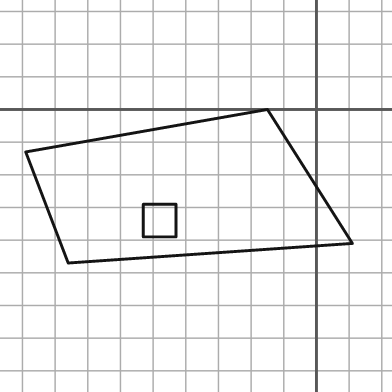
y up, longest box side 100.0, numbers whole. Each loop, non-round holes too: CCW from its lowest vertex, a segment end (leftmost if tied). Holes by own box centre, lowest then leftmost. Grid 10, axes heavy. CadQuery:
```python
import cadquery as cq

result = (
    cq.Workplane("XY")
    .moveTo(-76.0, -47.0)
    .lineTo(11.0, -41.0)
    .lineTo(-15.0, 0.0)
    .lineTo(-89.0, -13.0)
    .close()
    .moveTo(-53.0, -39.0)
    .lineTo(-43.0, -39.0)
    .lineTo(-43.0, -29.0)
    .lineTo(-53.0, -29.0)
    .close()
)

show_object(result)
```